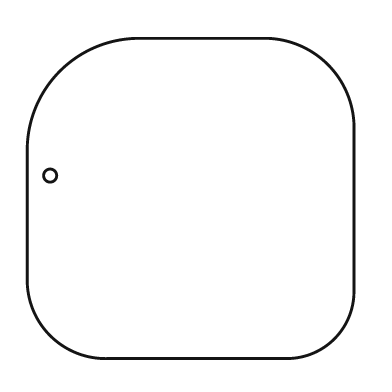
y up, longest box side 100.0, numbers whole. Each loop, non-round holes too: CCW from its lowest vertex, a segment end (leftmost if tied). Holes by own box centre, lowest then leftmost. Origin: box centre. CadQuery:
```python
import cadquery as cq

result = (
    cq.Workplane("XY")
    .moveTo(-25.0, -49.0)
    .lineTo(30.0, -49.0)
    .threePointArc((44.0, -43.0), (50.0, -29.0))
    .lineTo(50.0, 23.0)
    .threePointArc((42.0, 41.0), (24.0, 49.0))
    .lineTo(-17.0, 49.0)
    .threePointArc((-40.0, 39.0), (-50.0, 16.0))
    .lineTo(-50.0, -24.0)
    .threePointArc((-43.0, -42.0), (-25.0, -49.0))
    .close()
    .moveTo(-43.0, 7.0)
    .circle(2.0)
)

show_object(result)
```